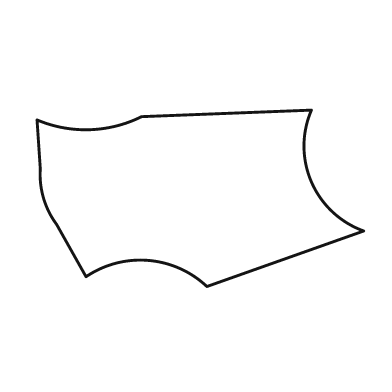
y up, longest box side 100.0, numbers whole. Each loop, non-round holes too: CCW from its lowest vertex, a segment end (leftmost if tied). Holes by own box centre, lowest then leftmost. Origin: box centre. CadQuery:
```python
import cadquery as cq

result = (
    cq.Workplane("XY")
    .moveTo(2.0, -27.0)
    .lineTo(50.0, -10.0)
    .threePointArc((34.0, 5.0), (34.0, 27.0))
    .lineTo(-18.0, 25.0)
    .threePointArc((-34.0, 21.0), (-50.0, 24.0))
    .lineTo(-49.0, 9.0)
    .threePointArc((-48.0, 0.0), (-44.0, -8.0))
    .lineTo(-35.0, -24.0)
    .threePointArc((-16.0, -19.0), (2.0, -27.0))
    .close()
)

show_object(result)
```